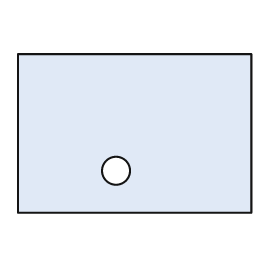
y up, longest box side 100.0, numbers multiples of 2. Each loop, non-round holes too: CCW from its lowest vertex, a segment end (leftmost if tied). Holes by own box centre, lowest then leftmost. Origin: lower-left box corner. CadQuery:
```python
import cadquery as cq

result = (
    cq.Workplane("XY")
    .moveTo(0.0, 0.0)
    .lineTo(100.0, 0.0)
    .lineTo(100.0, 68.0)
    .lineTo(0.0, 68.0)
    .close()
    .moveTo(42.0, 18.0)
    .circle(6.0)
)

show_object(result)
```